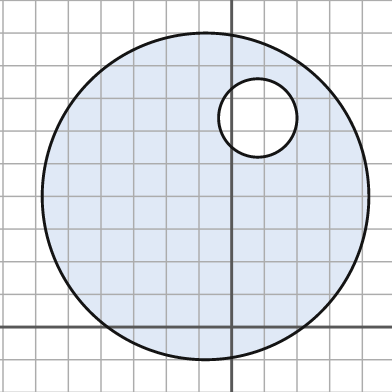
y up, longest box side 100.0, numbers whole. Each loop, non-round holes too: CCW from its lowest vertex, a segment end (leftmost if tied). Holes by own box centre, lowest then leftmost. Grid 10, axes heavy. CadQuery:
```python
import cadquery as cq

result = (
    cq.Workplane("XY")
    .moveTo(-8.0, 40.0)
    .circle(50.0)
    .moveTo(8.0, 64.0)
    .circle(12.0)
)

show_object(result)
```